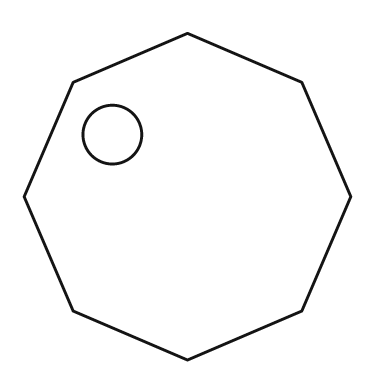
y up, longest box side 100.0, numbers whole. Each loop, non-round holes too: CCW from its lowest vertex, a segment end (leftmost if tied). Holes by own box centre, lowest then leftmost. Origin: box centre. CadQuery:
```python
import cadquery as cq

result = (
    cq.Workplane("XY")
    .moveTo(0.0, -50.0)
    .lineTo(35.0, -35.0)
    .lineTo(50.0, 0.0)
    .lineTo(35.0, 35.0)
    .lineTo(0.0, 50.0)
    .lineTo(-35.0, 35.0)
    .lineTo(-50.0, 0.0)
    .lineTo(-35.0, -35.0)
    .close()
    .moveTo(-23.0, 19.0)
    .circle(9.0)
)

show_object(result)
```